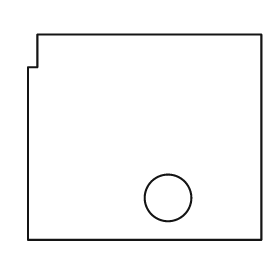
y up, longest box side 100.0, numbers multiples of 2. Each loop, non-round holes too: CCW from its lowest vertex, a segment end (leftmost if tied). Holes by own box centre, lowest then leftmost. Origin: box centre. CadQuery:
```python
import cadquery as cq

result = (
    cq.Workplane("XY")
    .moveTo(-50.0, -44.0)
    .lineTo(50.0, -44.0)
    .lineTo(50.0, 44.0)
    .lineTo(-46.0, 44.0)
    .lineTo(-46.0, 30.0)
    .lineTo(-50.0, 30.0)
    .close()
    .moveTo(10.0, -26.0)
    .circle(10.0)
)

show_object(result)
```